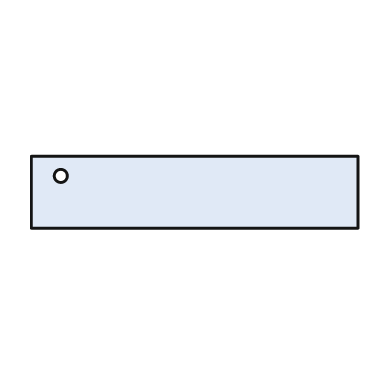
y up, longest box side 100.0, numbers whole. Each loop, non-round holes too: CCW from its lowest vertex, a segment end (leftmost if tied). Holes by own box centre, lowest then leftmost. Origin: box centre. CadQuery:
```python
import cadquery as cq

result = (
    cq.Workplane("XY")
    .moveTo(-50.0, -11.0)
    .lineTo(50.0, -11.0)
    .lineTo(50.0, 11.0)
    .lineTo(-50.0, 11.0)
    .close()
    .moveTo(-41.0, 5.0)
    .circle(2.0)
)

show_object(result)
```